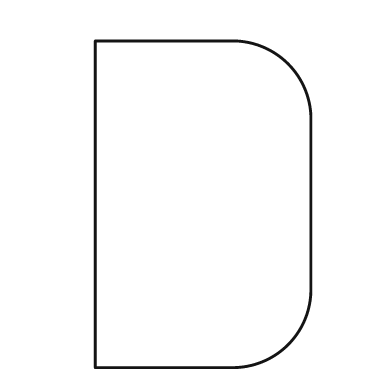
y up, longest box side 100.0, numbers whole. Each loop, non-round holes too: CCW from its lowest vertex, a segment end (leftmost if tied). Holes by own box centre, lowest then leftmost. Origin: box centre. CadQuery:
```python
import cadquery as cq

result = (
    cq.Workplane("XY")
    .moveTo(-33.0, -50.0)
    .lineTo(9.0, -50.0)
    .threePointArc((26.0, -43.0), (33.0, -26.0))
    .lineTo(33.0, 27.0)
    .threePointArc((26.0, 43.0), (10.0, 50.0))
    .lineTo(-33.0, 50.0)
    .close()
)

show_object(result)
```